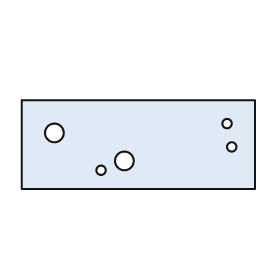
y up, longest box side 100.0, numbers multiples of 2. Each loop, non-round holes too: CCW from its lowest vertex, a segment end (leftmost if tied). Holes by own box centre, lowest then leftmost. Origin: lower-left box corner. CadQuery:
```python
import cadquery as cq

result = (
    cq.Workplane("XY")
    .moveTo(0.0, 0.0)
    .lineTo(100.0, 0.0)
    .lineTo(100.0, 38.0)
    .lineTo(0.0, 38.0)
    .close()
    .moveTo(34.0, 8.0)
    .circle(2.0)
    .moveTo(44.0, 12.0)
    .circle(4.0)
    .moveTo(90.0, 18.0)
    .circle(2.0)
    .moveTo(14.0, 24.0)
    .circle(4.0)
    .moveTo(88.0, 28.0)
    .circle(2.0)
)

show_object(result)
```